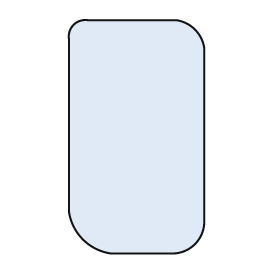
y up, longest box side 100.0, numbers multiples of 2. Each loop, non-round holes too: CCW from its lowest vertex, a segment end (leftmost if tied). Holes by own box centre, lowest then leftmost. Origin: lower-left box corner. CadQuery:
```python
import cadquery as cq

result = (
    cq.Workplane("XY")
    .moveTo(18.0, 0.0)
    .lineTo(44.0, 0.0)
    .threePointArc((54.0, 4.0), (58.0, 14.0))
    .lineTo(58.0, 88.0)
    .threePointArc((54.0, 96.0), (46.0, 100.0))
    .lineTo(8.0, 100.0)
    .threePointArc((2.0, 98.0), (0.0, 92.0))
    .lineTo(0.0, 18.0)
    .threePointArc((6.0, 6.0), (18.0, 0.0))
    .close()
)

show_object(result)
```